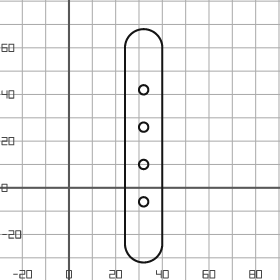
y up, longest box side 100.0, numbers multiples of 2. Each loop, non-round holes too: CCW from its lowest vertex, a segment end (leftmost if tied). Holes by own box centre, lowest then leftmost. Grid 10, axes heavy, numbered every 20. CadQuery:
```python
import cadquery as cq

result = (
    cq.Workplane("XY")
    .moveTo(24.0, -24.0)
    .threePointArc((32.0, -32.0), (40.0, -24.0))
    .lineTo(40.0, 60.0)
    .threePointArc((32.0, 68.0), (24.0, 60.0))
    .close()
    .moveTo(32.0, -6.0)
    .circle(2.0)
    .moveTo(32.0, 10.0)
    .circle(2.0)
    .moveTo(32.0, 26.0)
    .circle(2.0)
    .moveTo(32.0, 42.0)
    .circle(2.0)
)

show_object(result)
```